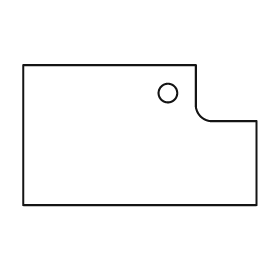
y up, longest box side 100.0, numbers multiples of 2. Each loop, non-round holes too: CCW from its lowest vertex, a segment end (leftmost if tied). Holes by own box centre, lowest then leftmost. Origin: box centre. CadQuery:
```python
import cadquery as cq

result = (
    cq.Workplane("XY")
    .moveTo(-50.0, -30.0)
    .lineTo(50.0, -30.0)
    .lineTo(50.0, 6.0)
    .lineTo(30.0, 6.0)
    .threePointArc((26.0, 8.0), (24.0, 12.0))
    .lineTo(24.0, 30.0)
    .lineTo(-50.0, 30.0)
    .close()
    .moveTo(12.0, 18.0)
    .circle(4.0)
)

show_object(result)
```